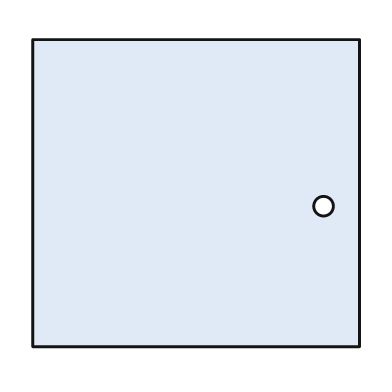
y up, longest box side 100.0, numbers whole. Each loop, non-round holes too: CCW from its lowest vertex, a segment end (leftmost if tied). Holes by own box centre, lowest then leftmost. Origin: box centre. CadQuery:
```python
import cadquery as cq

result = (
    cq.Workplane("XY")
    .moveTo(-50.0, -47.0)
    .lineTo(50.0, -47.0)
    .lineTo(50.0, 47.0)
    .lineTo(-50.0, 47.0)
    .close()
    .moveTo(39.0, -4.0)
    .circle(3.0)
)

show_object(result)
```